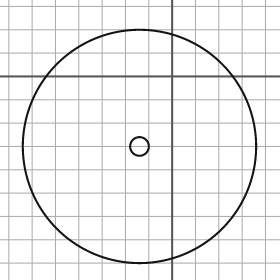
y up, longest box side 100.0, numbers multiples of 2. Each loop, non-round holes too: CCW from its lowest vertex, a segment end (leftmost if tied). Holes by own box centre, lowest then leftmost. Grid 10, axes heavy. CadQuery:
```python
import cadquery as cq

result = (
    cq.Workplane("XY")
    .moveTo(-14.0, -30.0)
    .circle(50.0)
    .moveTo(-14.0, -30.0)
    .circle(4.0)
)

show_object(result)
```